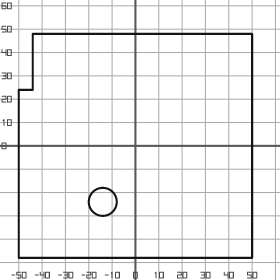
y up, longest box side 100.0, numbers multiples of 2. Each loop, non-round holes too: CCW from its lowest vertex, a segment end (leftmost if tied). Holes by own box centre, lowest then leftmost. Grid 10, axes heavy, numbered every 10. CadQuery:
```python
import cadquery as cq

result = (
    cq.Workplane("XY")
    .moveTo(-50.0, -48.0)
    .lineTo(50.0, -48.0)
    .lineTo(50.0, 48.0)
    .lineTo(-44.0, 48.0)
    .lineTo(-44.0, 24.0)
    .lineTo(-50.0, 24.0)
    .close()
    .moveTo(-14.0, -24.0)
    .circle(6.0)
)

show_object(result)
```